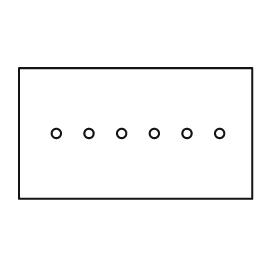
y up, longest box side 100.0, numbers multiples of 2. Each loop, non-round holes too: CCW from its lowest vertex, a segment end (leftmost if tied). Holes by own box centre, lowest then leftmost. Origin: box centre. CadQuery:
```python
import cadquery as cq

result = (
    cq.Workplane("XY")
    .moveTo(-50.0, -28.0)
    .lineTo(50.0, -28.0)
    .lineTo(50.0, 28.0)
    .lineTo(-50.0, 28.0)
    .close()
    .moveTo(-34.0, 0.0)
    .circle(2.0)
    .moveTo(-20.0, 0.0)
    .circle(2.0)
    .moveTo(-6.0, 0.0)
    .circle(2.0)
    .moveTo(8.0, 0.0)
    .circle(2.0)
    .moveTo(22.0, 0.0)
    .circle(2.0)
    .moveTo(36.0, 0.0)
    .circle(2.0)
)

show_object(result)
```